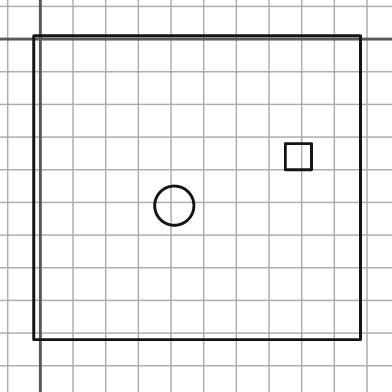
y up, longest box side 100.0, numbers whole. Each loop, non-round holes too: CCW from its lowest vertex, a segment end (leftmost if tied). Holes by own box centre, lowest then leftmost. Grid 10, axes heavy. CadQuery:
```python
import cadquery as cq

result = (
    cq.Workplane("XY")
    .moveTo(-2.0, -92.0)
    .lineTo(98.0, -92.0)
    .lineTo(98.0, 1.0)
    .lineTo(-2.0, 1.0)
    .close()
    .moveTo(41.0, -51.0)
    .circle(6.0)
    .moveTo(75.0, -40.0)
    .lineTo(83.0, -40.0)
    .lineTo(83.0, -32.0)
    .lineTo(75.0, -32.0)
    .close()
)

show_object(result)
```